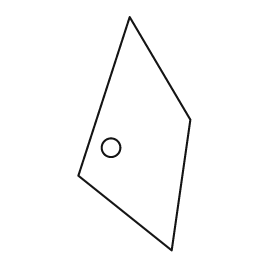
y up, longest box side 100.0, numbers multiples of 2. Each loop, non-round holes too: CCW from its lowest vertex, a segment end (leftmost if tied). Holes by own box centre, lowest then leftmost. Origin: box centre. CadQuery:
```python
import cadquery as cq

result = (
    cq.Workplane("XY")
    .moveTo(16.0, -50.0)
    .lineTo(24.0, 6.0)
    .lineTo(-2.0, 50.0)
    .lineTo(-24.0, -18.0)
    .close()
    .moveTo(-10.0, -6.0)
    .circle(4.0)
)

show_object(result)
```